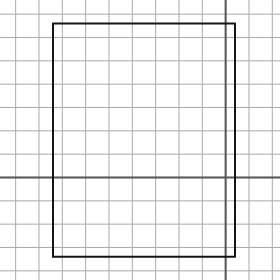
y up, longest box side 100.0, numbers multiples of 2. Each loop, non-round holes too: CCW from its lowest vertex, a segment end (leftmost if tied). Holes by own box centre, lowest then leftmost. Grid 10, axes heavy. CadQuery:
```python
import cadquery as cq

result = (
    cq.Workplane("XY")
    .moveTo(-74.0, -34.0)
    .lineTo(4.0, -34.0)
    .lineTo(4.0, 66.0)
    .lineTo(-74.0, 66.0)
    .close()
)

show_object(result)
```